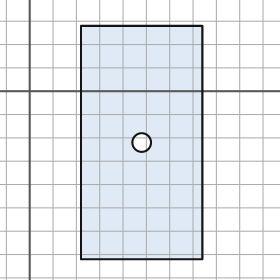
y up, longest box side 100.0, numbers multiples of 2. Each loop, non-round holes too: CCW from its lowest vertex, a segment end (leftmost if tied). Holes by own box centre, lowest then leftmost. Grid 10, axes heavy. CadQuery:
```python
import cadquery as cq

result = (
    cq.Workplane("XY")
    .moveTo(22.0, -72.0)
    .lineTo(74.0, -72.0)
    .lineTo(74.0, 28.0)
    .lineTo(22.0, 28.0)
    .close()
    .moveTo(48.0, -22.0)
    .circle(4.0)
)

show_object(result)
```